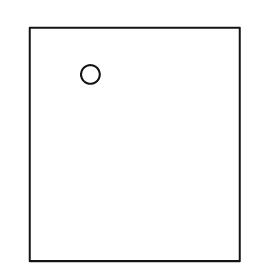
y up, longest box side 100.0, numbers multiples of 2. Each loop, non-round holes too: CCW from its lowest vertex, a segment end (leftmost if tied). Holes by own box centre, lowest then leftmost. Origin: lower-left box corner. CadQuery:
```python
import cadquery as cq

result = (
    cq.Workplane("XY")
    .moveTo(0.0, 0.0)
    .lineTo(90.0, 0.0)
    .lineTo(90.0, 100.0)
    .lineTo(0.0, 100.0)
    .close()
    .moveTo(26.0, 80.0)
    .circle(4.0)
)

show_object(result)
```